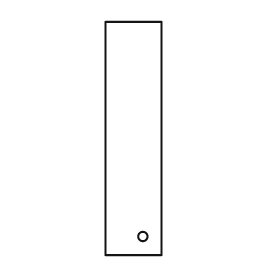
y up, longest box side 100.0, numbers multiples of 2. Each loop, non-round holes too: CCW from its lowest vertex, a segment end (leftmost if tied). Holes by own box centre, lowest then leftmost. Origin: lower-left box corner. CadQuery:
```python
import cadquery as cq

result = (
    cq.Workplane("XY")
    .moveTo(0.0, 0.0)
    .lineTo(24.0, 0.0)
    .lineTo(24.0, 100.0)
    .lineTo(0.0, 100.0)
    .close()
    .moveTo(16.0, 8.0)
    .circle(2.0)
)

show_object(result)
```